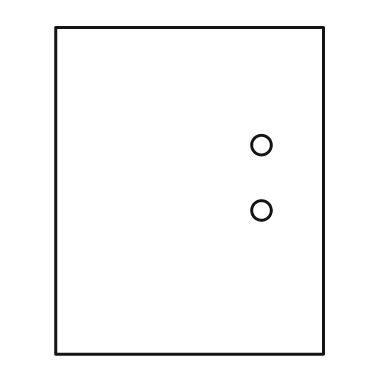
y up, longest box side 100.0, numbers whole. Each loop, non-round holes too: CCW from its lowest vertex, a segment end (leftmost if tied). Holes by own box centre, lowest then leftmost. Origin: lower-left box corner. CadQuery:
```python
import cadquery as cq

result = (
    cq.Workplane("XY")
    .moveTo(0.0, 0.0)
    .lineTo(82.0, 0.0)
    .lineTo(82.0, 100.0)
    .lineTo(0.0, 100.0)
    .close()
    .moveTo(63.0, 44.0)
    .circle(3.0)
    .moveTo(63.0, 64.0)
    .circle(3.0)
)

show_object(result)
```